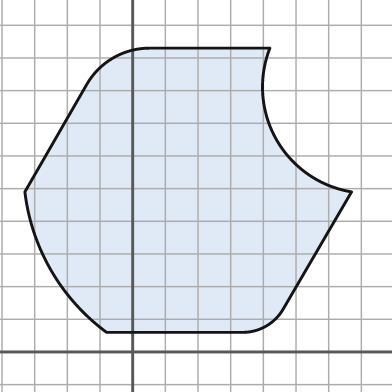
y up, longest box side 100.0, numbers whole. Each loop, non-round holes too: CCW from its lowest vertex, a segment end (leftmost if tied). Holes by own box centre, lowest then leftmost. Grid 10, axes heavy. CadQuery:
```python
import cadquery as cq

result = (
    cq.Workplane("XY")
    .moveTo(-8.0, 6.0)
    .lineTo(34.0, 6.0)
    .threePointArc((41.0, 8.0), (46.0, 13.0))
    .lineTo(67.0, 49.0)
    .threePointArc((44.0, 65.0), (42.0, 93.0))
    .lineTo(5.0, 93.0)
    .threePointArc((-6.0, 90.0), (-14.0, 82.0))
    .lineTo(-33.0, 49.0)
    .threePointArc((-25.0, 25.0), (-8.0, 6.0))
    .close()
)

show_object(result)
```